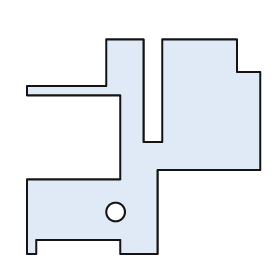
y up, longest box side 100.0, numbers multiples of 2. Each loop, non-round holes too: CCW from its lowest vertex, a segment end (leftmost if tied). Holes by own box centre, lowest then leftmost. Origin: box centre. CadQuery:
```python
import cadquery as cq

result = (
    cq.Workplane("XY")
    .moveTo(-50.0, -46.0)
    .lineTo(-46.0, -46.0)
    .lineTo(-46.0, -40.0)
    .lineTo(-10.0, -40.0)
    .lineTo(-10.0, -46.0)
    .lineTo(6.0, -46.0)
    .lineTo(6.0, -10.0)
    .lineTo(50.0, -10.0)
    .lineTo(50.0, 32.0)
    .lineTo(40.0, 32.0)
    .lineTo(40.0, 46.0)
    .lineTo(8.0, 46.0)
    .lineTo(8.0, 2.0)
    .lineTo(0.0, 2.0)
    .lineTo(0.0, 46.0)
    .lineTo(-16.0, 46.0)
    .lineTo(-16.0, 26.0)
    .lineTo(-50.0, 26.0)
    .lineTo(-50.0, 22.0)
    .lineTo(-10.0, 22.0)
    .lineTo(-10.0, -14.0)
    .lineTo(-50.0, -14.0)
    .close()
    .moveTo(-12.0, -28.0)
    .circle(4.0)
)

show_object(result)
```